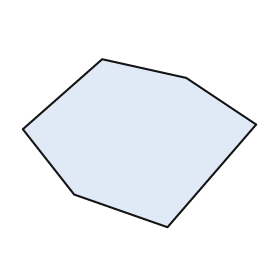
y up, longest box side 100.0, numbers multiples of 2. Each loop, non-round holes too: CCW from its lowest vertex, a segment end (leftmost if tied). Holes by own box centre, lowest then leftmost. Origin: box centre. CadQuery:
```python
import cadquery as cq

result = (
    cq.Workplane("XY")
    .moveTo(12.0, -36.0)
    .lineTo(50.0, 8.0)
    .lineTo(20.0, 28.0)
    .lineTo(-16.0, 36.0)
    .lineTo(-50.0, 6.0)
    .lineTo(-28.0, -22.0)
    .close()
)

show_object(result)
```